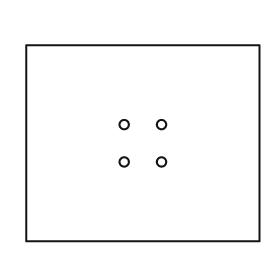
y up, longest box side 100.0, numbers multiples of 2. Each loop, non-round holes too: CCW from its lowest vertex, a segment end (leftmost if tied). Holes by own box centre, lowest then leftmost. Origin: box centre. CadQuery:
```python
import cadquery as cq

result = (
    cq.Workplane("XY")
    .moveTo(-50.0, -42.0)
    .lineTo(50.0, -42.0)
    .lineTo(50.0, 42.0)
    .lineTo(-50.0, 42.0)
    .close()
    .moveTo(-8.0, -8.0)
    .circle(2.0)
    .moveTo(8.0, -8.0)
    .circle(2.0)
    .moveTo(-8.0, 8.0)
    .circle(2.0)
    .moveTo(8.0, 8.0)
    .circle(2.0)
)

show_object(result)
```